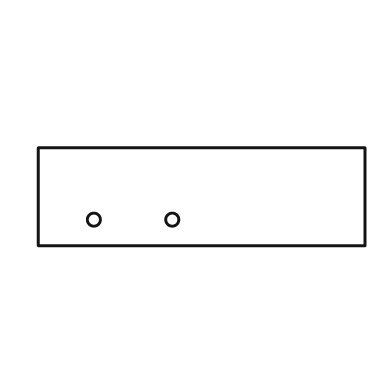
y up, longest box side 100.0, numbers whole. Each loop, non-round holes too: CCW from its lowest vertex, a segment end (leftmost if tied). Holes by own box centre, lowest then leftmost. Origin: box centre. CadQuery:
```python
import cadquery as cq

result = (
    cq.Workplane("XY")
    .moveTo(-50.0, -15.0)
    .lineTo(50.0, -15.0)
    .lineTo(50.0, 15.0)
    .lineTo(-50.0, 15.0)
    .close()
    .moveTo(-33.0, -7.0)
    .circle(2.0)
    .moveTo(-9.0, -7.0)
    .circle(2.0)
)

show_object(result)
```